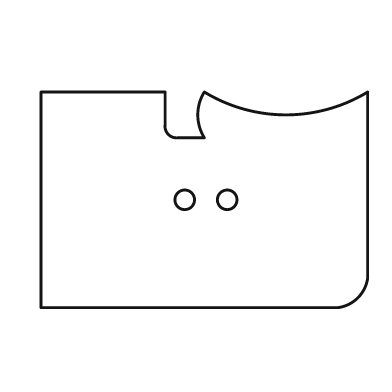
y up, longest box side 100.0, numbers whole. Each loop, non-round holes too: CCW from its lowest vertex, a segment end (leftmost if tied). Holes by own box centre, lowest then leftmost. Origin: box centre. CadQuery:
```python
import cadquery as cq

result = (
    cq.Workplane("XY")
    .moveTo(-50.0, -33.0)
    .lineTo(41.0, -33.0)
    .threePointArc((47.0, -30.0), (50.0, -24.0))
    .lineTo(50.0, 33.0)
    .threePointArc((25.0, 26.0), (0.0, 33.0))
    .threePointArc((-2.0, 26.0), (0.0, 19.0))
    .lineTo(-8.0, 19.0)
    .threePointArc((-11.0, 20.0), (-12.0, 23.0))
    .lineTo(-12.0, 33.0)
    .lineTo(-50.0, 33.0)
    .close()
    .moveTo(-6.0, 0.0)
    .circle(3.0)
    .moveTo(7.0, 0.0)
    .circle(3.0)
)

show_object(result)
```